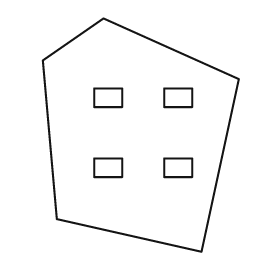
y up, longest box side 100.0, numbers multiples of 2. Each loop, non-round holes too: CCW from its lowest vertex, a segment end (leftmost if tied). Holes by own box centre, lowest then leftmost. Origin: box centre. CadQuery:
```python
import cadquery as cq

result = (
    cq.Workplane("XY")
    .moveTo(26.0, -50.0)
    .lineTo(42.0, 24.0)
    .lineTo(-16.0, 50.0)
    .lineTo(-42.0, 32.0)
    .lineTo(-36.0, -36.0)
    .close()
    .moveTo(-20.0, -18.0)
    .lineTo(-8.0, -18.0)
    .lineTo(-8.0, -10.0)
    .lineTo(-20.0, -10.0)
    .close()
    .moveTo(10.0, -18.0)
    .lineTo(22.0, -18.0)
    .lineTo(22.0, -10.0)
    .lineTo(10.0, -10.0)
    .close()
    .moveTo(-20.0, 12.0)
    .lineTo(-8.0, 12.0)
    .lineTo(-8.0, 20.0)
    .lineTo(-20.0, 20.0)
    .close()
    .moveTo(10.0, 12.0)
    .lineTo(22.0, 12.0)
    .lineTo(22.0, 20.0)
    .lineTo(10.0, 20.0)
    .close()
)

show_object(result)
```